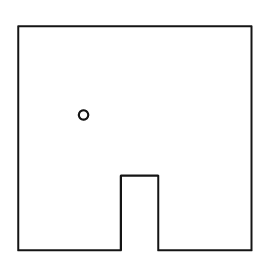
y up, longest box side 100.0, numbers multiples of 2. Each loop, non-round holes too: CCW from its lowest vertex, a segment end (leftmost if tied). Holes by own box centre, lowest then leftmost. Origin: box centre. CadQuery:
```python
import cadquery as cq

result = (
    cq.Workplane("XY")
    .moveTo(-50.0, -48.0)
    .lineTo(-6.0, -48.0)
    .lineTo(-6.0, -16.0)
    .lineTo(10.0, -16.0)
    .lineTo(10.0, -48.0)
    .lineTo(50.0, -48.0)
    .lineTo(50.0, 48.0)
    .lineTo(-50.0, 48.0)
    .close()
    .moveTo(-22.0, 10.0)
    .circle(2.0)
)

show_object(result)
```